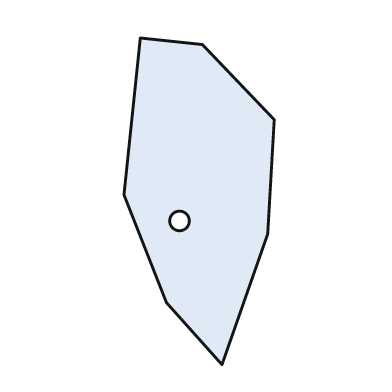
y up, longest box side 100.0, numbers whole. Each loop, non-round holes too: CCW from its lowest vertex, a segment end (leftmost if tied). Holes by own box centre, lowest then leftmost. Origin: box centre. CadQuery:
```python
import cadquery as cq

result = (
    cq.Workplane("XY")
    .moveTo(7.0, -50.0)
    .lineTo(21.0, -10.0)
    .lineTo(23.0, 25.0)
    .lineTo(1.0, 48.0)
    .lineTo(-18.0, 50.0)
    .lineTo(-23.0, 2.0)
    .lineTo(-10.0, -31.0)
    .close()
    .moveTo(-6.0, -6.0)
    .circle(3.0)
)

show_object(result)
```